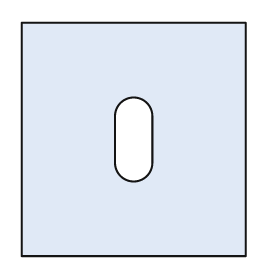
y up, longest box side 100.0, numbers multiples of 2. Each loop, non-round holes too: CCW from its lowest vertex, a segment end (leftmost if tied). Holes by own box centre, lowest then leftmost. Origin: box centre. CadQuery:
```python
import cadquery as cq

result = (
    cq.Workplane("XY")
    .moveTo(-48.0, -50.0)
    .lineTo(48.0, -50.0)
    .lineTo(48.0, 50.0)
    .lineTo(-48.0, 50.0)
    .close()
    .moveTo(-8.0, -10.0)
    .threePointArc((0.0, -18.0), (8.0, -10.0))
    .lineTo(8.0, 10.0)
    .threePointArc((0.0, 18.0), (-8.0, 10.0))
    .close()
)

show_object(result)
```